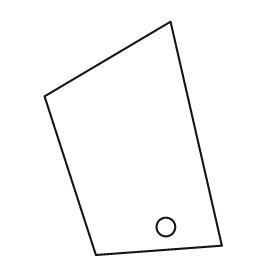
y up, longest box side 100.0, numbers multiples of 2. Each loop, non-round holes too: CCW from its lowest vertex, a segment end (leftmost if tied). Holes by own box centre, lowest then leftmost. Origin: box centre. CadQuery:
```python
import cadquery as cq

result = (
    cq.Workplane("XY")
    .moveTo(-16.0, -50.0)
    .lineTo(38.0, -46.0)
    .lineTo(16.0, 50.0)
    .lineTo(-38.0, 18.0)
    .close()
    .moveTo(14.0, -38.0)
    .circle(4.0)
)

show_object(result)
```